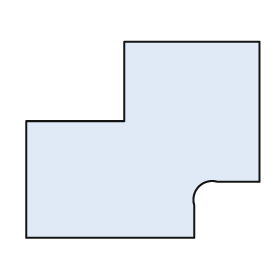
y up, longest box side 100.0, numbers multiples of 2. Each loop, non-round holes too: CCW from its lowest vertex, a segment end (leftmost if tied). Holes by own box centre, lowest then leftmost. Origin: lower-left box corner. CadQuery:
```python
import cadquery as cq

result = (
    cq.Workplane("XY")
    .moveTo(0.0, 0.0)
    .lineTo(72.0, 0.0)
    .lineTo(72.0, 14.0)
    .threePointArc((74.0, 22.0), (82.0, 24.0))
    .lineTo(100.0, 24.0)
    .lineTo(100.0, 84.0)
    .lineTo(42.0, 84.0)
    .lineTo(42.0, 50.0)
    .lineTo(0.0, 50.0)
    .close()
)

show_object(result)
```